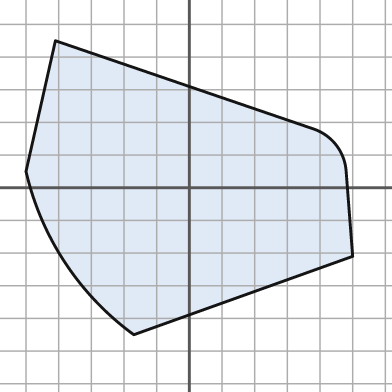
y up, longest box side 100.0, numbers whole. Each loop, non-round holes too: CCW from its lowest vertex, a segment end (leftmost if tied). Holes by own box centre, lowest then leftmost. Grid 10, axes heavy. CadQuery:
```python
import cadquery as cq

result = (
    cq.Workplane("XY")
    .moveTo(-17.0, -45.0)
    .lineTo(50.0, -21.0)
    .lineTo(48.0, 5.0)
    .threePointArc((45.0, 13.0), (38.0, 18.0))
    .lineTo(-41.0, 45.0)
    .lineTo(-50.0, 5.0)
    .threePointArc((-38.0, -23.0), (-17.0, -45.0))
    .close()
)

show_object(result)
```